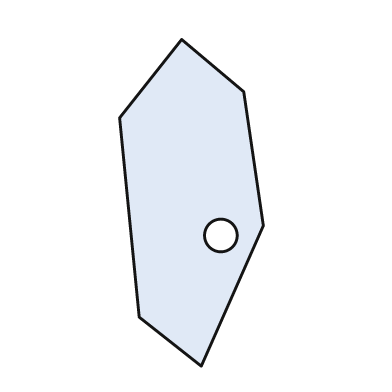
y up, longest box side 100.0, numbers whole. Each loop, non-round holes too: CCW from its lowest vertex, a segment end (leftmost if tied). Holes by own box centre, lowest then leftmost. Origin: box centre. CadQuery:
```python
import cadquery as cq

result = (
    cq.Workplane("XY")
    .moveTo(3.0, -50.0)
    .lineTo(22.0, -7.0)
    .lineTo(16.0, 34.0)
    .lineTo(-3.0, 50.0)
    .lineTo(-22.0, 26.0)
    .lineTo(-16.0, -35.0)
    .close()
    .moveTo(9.0, -10.0)
    .circle(5.0)
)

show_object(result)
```